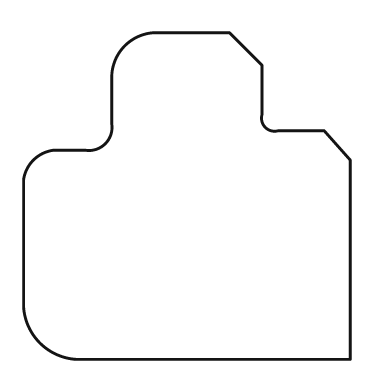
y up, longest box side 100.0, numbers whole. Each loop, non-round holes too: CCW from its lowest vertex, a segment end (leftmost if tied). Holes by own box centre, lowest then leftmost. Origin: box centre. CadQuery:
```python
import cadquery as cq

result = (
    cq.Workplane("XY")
    .moveTo(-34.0, -50.0)
    .lineTo(50.0, -50.0)
    .lineTo(50.0, 11.0)
    .lineTo(42.0, 20.0)
    .lineTo(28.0, 20.0)
    .threePointArc((24.0, 21.0), (23.0, 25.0))
    .lineTo(23.0, 40.0)
    .lineTo(13.0, 50.0)
    .lineTo(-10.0, 50.0)
    .threePointArc((-19.0, 46.0), (-23.0, 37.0))
    .lineTo(-23.0, 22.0)
    .threePointArc((-25.0, 16.0), (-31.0, 14.0))
    .lineTo(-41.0, 14.0)
    .threePointArc((-47.0, 11.0), (-50.0, 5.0))
    .lineTo(-50.0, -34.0)
    .threePointArc((-45.0, -45.0), (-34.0, -50.0))
    .close()
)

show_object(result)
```